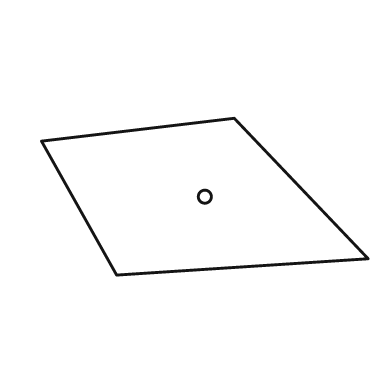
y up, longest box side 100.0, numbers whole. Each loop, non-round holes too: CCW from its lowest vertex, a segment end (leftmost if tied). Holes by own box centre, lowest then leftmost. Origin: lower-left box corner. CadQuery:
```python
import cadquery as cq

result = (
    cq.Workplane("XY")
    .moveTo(23.0, 0.0)
    .lineTo(100.0, 5.0)
    .lineTo(59.0, 48.0)
    .lineTo(0.0, 41.0)
    .close()
    .moveTo(50.0, 24.0)
    .circle(2.0)
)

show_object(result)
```